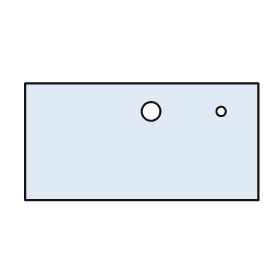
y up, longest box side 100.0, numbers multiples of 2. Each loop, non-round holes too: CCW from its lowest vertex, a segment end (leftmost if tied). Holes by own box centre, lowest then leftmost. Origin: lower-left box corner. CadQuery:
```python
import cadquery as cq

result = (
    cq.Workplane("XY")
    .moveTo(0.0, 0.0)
    .lineTo(100.0, 0.0)
    .lineTo(100.0, 50.0)
    .lineTo(0.0, 50.0)
    .close()
    .moveTo(54.0, 38.0)
    .circle(4.0)
    .moveTo(84.0, 38.0)
    .circle(2.0)
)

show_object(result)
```